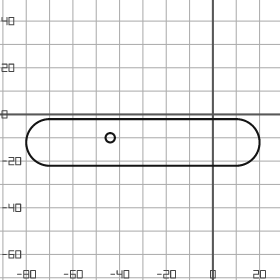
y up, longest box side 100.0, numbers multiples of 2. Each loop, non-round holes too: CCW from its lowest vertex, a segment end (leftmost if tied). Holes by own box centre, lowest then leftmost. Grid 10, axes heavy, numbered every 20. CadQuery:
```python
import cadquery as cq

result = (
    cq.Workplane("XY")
    .moveTo(-70.0, -22.0)
    .lineTo(10.0, -22.0)
    .threePointArc((20.0, -12.0), (10.0, -2.0))
    .lineTo(-70.0, -2.0)
    .threePointArc((-80.0, -12.0), (-70.0, -22.0))
    .close()
    .moveTo(-44.0, -10.0)
    .circle(2.0)
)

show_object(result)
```